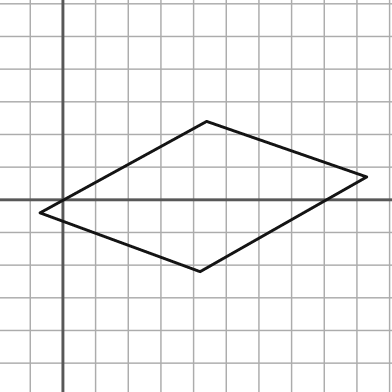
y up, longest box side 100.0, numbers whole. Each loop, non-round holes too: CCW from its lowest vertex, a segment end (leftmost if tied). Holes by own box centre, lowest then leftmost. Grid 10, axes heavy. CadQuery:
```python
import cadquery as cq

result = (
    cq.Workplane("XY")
    .moveTo(42.0, -22.0)
    .lineTo(93.0, 7.0)
    .lineTo(44.0, 24.0)
    .lineTo(-7.0, -4.0)
    .close()
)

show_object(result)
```